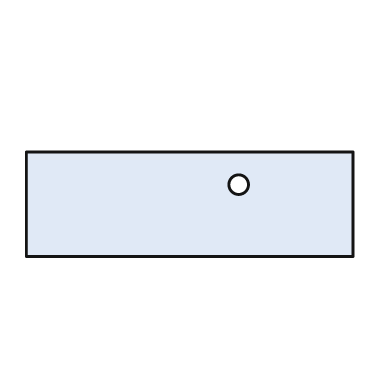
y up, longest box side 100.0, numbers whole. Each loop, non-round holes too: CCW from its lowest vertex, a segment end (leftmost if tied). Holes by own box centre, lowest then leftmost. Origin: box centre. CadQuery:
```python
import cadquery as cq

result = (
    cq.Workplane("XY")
    .moveTo(-50.0, -16.0)
    .lineTo(50.0, -16.0)
    .lineTo(50.0, 16.0)
    .lineTo(-50.0, 16.0)
    .close()
    .moveTo(15.0, 6.0)
    .circle(3.0)
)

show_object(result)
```